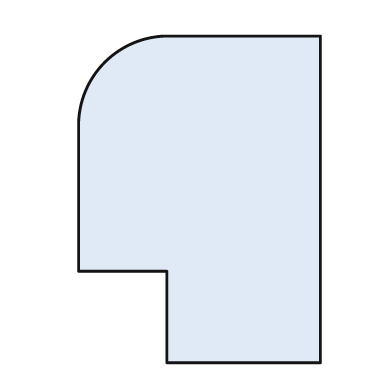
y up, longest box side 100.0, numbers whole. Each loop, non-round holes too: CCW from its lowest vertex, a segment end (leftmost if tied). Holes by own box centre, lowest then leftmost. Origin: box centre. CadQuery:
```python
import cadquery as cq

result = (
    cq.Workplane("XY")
    .moveTo(-10.0, -50.0)
    .lineTo(37.0, -50.0)
    .lineTo(37.0, 50.0)
    .lineTo(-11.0, 50.0)
    .threePointArc((-29.0, 42.0), (-37.0, 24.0))
    .lineTo(-37.0, -22.0)
    .lineTo(-10.0, -22.0)
    .close()
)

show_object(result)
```